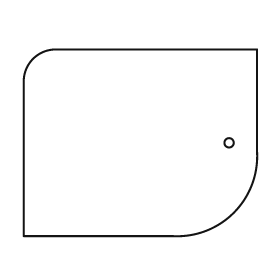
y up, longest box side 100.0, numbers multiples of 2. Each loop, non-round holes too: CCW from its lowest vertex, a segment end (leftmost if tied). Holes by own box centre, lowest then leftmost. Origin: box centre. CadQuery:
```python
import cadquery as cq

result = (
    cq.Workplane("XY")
    .moveTo(-50.0, -40.0)
    .lineTo(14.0, -40.0)
    .threePointArc((40.0, -30.0), (50.0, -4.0))
    .lineTo(50.0, 40.0)
    .lineTo(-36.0, 40.0)
    .threePointArc((-46.0, 36.0), (-50.0, 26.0))
    .close()
    .moveTo(38.0, 0.0)
    .circle(2.0)
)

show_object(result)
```